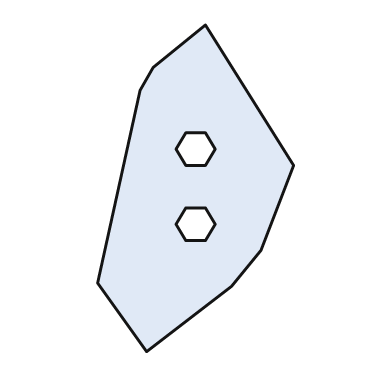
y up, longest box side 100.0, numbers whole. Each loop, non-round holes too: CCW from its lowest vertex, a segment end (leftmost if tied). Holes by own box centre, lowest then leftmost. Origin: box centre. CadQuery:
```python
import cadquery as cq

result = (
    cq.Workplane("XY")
    .moveTo(-15.0, -50.0)
    .lineTo(11.0, -30.0)
    .lineTo(20.0, -19.0)
    .lineTo(30.0, 7.0)
    .lineTo(3.0, 50.0)
    .lineTo(-13.0, 37.0)
    .lineTo(-17.0, 30.0)
    .lineTo(-30.0, -29.0)
    .close()
    .moveTo(-3.0, -16.0)
    .lineTo(3.0, -16.0)
    .lineTo(6.0, -11.0)
    .lineTo(3.0, -6.0)
    .lineTo(-3.0, -6.0)
    .lineTo(-6.0, -11.0)
    .close()
    .moveTo(-3.0, 7.0)
    .lineTo(3.0, 7.0)
    .lineTo(6.0, 12.0)
    .lineTo(3.0, 17.0)
    .lineTo(-3.0, 17.0)
    .lineTo(-6.0, 12.0)
    .close()
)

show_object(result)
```